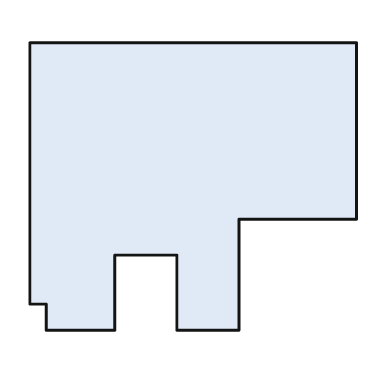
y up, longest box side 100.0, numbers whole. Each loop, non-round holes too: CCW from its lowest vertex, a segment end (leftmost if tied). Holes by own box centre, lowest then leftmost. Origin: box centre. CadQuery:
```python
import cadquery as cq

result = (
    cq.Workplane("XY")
    .moveTo(-45.0, -44.0)
    .lineTo(-24.0, -44.0)
    .lineTo(-24.0, -21.0)
    .lineTo(-5.0, -21.0)
    .lineTo(-5.0, -44.0)
    .lineTo(14.0, -44.0)
    .lineTo(14.0, -10.0)
    .lineTo(50.0, -10.0)
    .lineTo(50.0, 44.0)
    .lineTo(-50.0, 44.0)
    .lineTo(-50.0, -36.0)
    .lineTo(-45.0, -36.0)
    .close()
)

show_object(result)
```